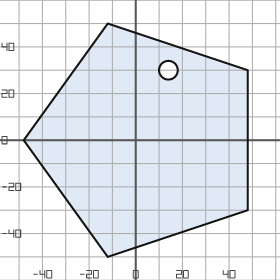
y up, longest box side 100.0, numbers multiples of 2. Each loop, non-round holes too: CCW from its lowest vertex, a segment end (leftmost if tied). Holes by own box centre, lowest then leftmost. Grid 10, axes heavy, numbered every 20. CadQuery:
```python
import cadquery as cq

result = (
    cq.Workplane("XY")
    .moveTo(-12.0, -50.0)
    .lineTo(48.0, -30.0)
    .lineTo(48.0, 30.0)
    .lineTo(-12.0, 50.0)
    .lineTo(-48.0, 0.0)
    .close()
    .moveTo(14.0, 30.0)
    .circle(4.0)
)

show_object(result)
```